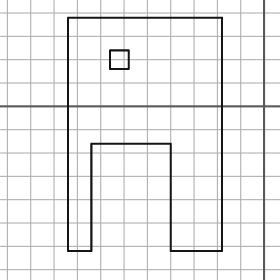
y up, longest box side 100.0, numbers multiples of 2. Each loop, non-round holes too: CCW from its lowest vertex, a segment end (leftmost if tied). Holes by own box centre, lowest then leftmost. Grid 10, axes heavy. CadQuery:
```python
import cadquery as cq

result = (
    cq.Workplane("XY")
    .moveTo(-84.0, -62.0)
    .lineTo(-74.0, -62.0)
    .lineTo(-74.0, -16.0)
    .lineTo(-40.0, -16.0)
    .lineTo(-40.0, -62.0)
    .lineTo(-18.0, -62.0)
    .lineTo(-18.0, 38.0)
    .lineTo(-84.0, 38.0)
    .close()
    .moveTo(-66.0, 16.0)
    .lineTo(-58.0, 16.0)
    .lineTo(-58.0, 24.0)
    .lineTo(-66.0, 24.0)
    .close()
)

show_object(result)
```